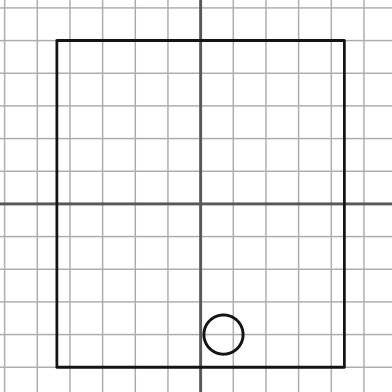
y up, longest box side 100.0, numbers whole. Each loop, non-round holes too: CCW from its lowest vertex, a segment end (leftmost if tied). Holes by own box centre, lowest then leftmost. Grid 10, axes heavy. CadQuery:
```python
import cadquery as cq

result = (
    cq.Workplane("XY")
    .moveTo(-44.0, -50.0)
    .lineTo(44.0, -50.0)
    .lineTo(44.0, 50.0)
    .lineTo(-44.0, 50.0)
    .close()
    .moveTo(7.0, -40.0)
    .circle(6.0)
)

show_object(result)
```